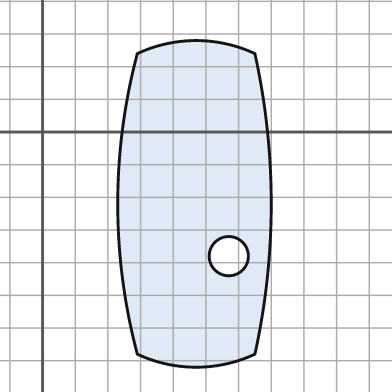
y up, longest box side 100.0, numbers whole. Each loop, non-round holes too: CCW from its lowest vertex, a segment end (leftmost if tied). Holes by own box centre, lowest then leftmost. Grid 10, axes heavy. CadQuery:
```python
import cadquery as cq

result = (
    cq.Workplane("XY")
    .moveTo(29.0, -68.0)
    .threePointArc((47.0, -72.0), (65.0, -68.0))
    .threePointArc((70.0, -22.0), (65.0, 24.0))
    .threePointArc((47.0, 28.0), (29.0, 24.0))
    .threePointArc((23.0, -22.0), (29.0, -68.0))
    .close()
    .moveTo(57.0, -38.0)
    .circle(6.0)
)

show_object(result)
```